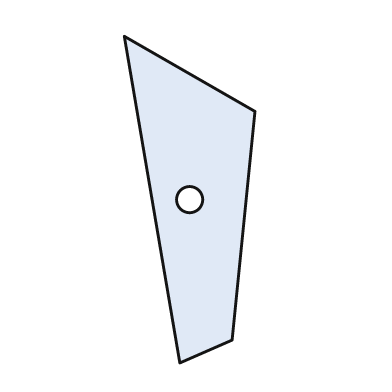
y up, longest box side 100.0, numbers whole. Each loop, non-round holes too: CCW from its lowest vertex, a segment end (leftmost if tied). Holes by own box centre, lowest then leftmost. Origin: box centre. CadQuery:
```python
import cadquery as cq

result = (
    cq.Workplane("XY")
    .moveTo(-3.0, -50.0)
    .lineTo(13.0, -43.0)
    .lineTo(20.0, 27.0)
    .lineTo(-20.0, 50.0)
    .close()
    .moveTo(0.0, 0.0)
    .circle(4.0)
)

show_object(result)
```